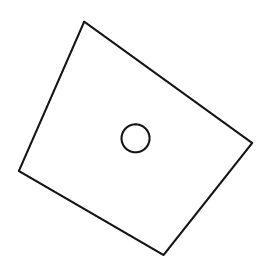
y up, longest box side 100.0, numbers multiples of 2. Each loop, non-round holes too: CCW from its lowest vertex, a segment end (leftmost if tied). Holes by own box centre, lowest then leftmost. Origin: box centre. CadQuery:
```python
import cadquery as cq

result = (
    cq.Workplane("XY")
    .moveTo(12.0, -50.0)
    .lineTo(50.0, -2.0)
    .lineTo(-22.0, 50.0)
    .lineTo(-50.0, -14.0)
    .close()
    .moveTo(0.0, 0.0)
    .circle(6.0)
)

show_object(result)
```